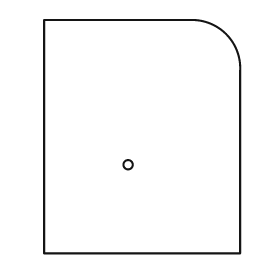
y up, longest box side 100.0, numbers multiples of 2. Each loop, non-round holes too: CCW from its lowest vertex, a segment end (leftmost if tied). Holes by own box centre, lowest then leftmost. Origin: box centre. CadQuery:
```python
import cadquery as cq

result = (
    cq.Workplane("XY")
    .moveTo(-42.0, -50.0)
    .lineTo(42.0, -50.0)
    .lineTo(42.0, 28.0)
    .threePointArc((36.0, 44.0), (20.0, 50.0))
    .lineTo(-42.0, 50.0)
    .close()
    .moveTo(-6.0, -12.0)
    .circle(2.0)
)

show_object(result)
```